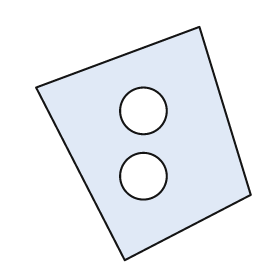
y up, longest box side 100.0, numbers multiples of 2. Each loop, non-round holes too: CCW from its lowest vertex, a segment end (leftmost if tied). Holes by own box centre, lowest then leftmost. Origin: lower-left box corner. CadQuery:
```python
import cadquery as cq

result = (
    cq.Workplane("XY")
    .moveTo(38.0, 0.0)
    .lineTo(92.0, 28.0)
    .lineTo(70.0, 100.0)
    .lineTo(0.0, 74.0)
    .close()
    .moveTo(46.0, 36.0)
    .circle(10.0)
    .moveTo(46.0, 64.0)
    .circle(10.0)
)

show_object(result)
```